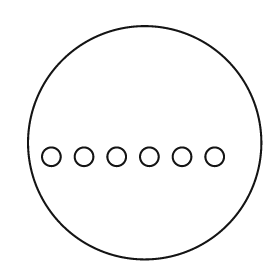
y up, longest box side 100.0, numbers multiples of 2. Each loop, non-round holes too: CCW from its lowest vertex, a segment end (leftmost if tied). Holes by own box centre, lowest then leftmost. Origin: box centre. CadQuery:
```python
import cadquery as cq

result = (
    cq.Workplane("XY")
    .moveTo(0.0, 0.0)
    .circle(50.0)
    .moveTo(-40.0, -6.0)
    .circle(4.0)
    .moveTo(-26.0, -6.0)
    .circle(4.0)
    .moveTo(-12.0, -6.0)
    .circle(4.0)
    .moveTo(2.0, -6.0)
    .circle(4.0)
    .moveTo(16.0, -6.0)
    .circle(4.0)
    .moveTo(30.0, -6.0)
    .circle(4.0)
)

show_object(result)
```